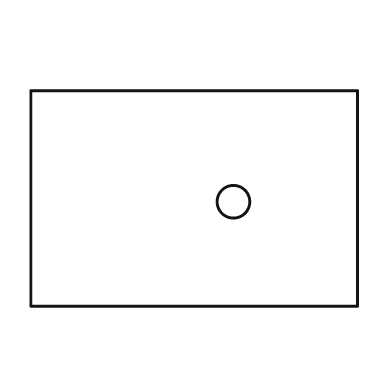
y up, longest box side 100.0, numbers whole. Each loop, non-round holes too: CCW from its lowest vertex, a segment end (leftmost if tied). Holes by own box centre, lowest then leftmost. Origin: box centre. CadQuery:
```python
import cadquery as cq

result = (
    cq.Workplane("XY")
    .moveTo(-50.0, -33.0)
    .lineTo(50.0, -33.0)
    .lineTo(50.0, 33.0)
    .lineTo(-50.0, 33.0)
    .close()
    .moveTo(12.0, -1.0)
    .circle(5.0)
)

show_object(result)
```